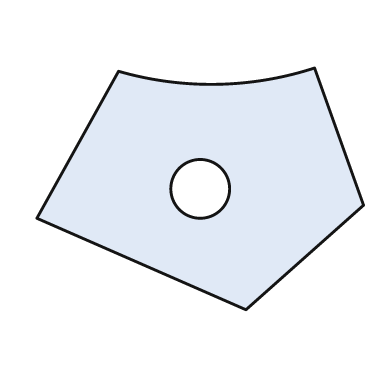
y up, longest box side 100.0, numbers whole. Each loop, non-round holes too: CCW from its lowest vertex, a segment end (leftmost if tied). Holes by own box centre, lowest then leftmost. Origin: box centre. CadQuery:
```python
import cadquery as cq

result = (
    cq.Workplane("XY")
    .moveTo(14.0, -37.0)
    .lineTo(50.0, -5.0)
    .lineTo(35.0, 37.0)
    .threePointArc((5.0, 32.0), (-25.0, 36.0))
    .lineTo(-50.0, -9.0)
    .close()
    .moveTo(0.0, 0.0)
    .circle(9.0)
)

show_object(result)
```